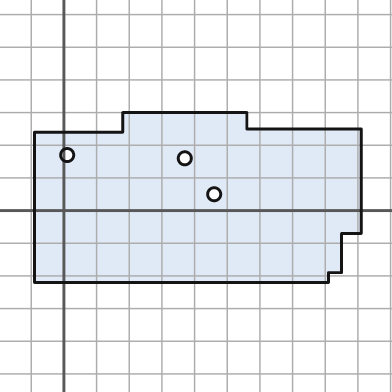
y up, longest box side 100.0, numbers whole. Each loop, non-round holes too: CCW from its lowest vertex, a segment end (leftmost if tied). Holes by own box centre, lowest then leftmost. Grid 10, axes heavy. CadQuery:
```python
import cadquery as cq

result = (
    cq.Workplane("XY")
    .moveTo(-9.0, -22.0)
    .lineTo(81.0, -22.0)
    .lineTo(81.0, -19.0)
    .lineTo(85.0, -19.0)
    .lineTo(85.0, -7.0)
    .lineTo(91.0, -7.0)
    .lineTo(91.0, 25.0)
    .lineTo(56.0, 25.0)
    .lineTo(56.0, 30.0)
    .lineTo(18.0, 30.0)
    .lineTo(18.0, 24.0)
    .lineTo(-9.0, 24.0)
    .close()
    .moveTo(46.0, 5.0)
    .circle(2.0)
    .moveTo(37.0, 16.0)
    .circle(2.0)
    .moveTo(1.0, 17.0)
    .circle(2.0)
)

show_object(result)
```